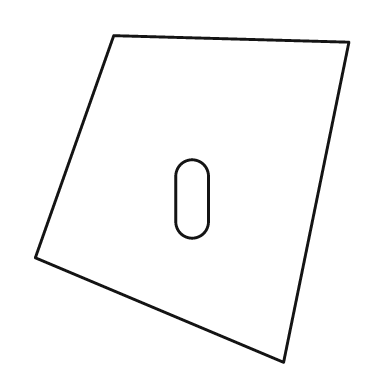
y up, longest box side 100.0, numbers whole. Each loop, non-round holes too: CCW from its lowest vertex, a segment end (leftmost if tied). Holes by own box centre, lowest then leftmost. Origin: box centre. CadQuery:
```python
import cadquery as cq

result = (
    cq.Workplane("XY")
    .moveTo(28.0, -50.0)
    .lineTo(48.0, 48.0)
    .lineTo(-24.0, 50.0)
    .lineTo(-48.0, -18.0)
    .close()
    .moveTo(-5.0, -7.0)
    .threePointArc((0.0, -12.0), (5.0, -7.0))
    .lineTo(5.0, 7.0)
    .threePointArc((0.0, 12.0), (-5.0, 7.0))
    .close()
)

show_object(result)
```